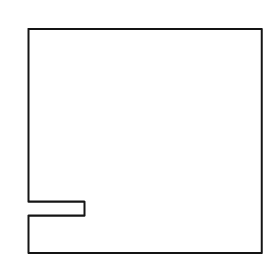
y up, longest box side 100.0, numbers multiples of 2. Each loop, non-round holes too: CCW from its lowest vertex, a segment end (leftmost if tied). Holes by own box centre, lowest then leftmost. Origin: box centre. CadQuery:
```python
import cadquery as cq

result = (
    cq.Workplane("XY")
    .moveTo(-50.0, -48.0)
    .lineTo(50.0, -48.0)
    .lineTo(50.0, 48.0)
    .lineTo(-50.0, 48.0)
    .lineTo(-50.0, -26.0)
    .lineTo(-26.0, -26.0)
    .lineTo(-26.0, -32.0)
    .lineTo(-50.0, -32.0)
    .close()
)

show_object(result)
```